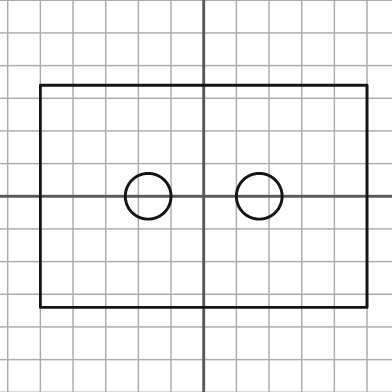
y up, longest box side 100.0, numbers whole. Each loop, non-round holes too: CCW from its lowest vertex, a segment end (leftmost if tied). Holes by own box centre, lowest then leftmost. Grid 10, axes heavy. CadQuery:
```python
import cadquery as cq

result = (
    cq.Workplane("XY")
    .moveTo(-50.0, -34.0)
    .lineTo(50.0, -34.0)
    .lineTo(50.0, 34.0)
    .lineTo(-50.0, 34.0)
    .close()
    .moveTo(-17.0, 0.0)
    .circle(7.0)
    .moveTo(17.0, 0.0)
    .circle(7.0)
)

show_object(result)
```